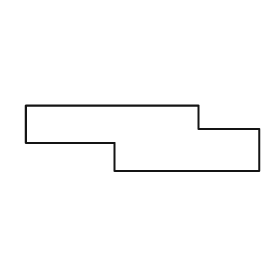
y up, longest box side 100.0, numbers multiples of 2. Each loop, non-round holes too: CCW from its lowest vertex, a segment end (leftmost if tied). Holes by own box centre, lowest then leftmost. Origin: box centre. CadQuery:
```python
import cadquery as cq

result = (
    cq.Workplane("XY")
    .moveTo(-12.0, -14.0)
    .lineTo(50.0, -14.0)
    .lineTo(50.0, 4.0)
    .lineTo(24.0, 4.0)
    .lineTo(24.0, 14.0)
    .lineTo(-50.0, 14.0)
    .lineTo(-50.0, -2.0)
    .lineTo(-12.0, -2.0)
    .close()
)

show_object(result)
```